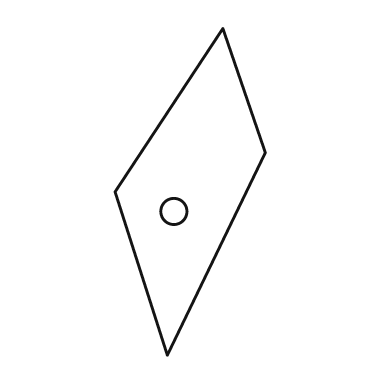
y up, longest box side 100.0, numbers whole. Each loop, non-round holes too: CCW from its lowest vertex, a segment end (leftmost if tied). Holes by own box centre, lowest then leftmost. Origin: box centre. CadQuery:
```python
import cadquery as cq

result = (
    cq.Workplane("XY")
    .moveTo(-7.0, -50.0)
    .lineTo(23.0, 12.0)
    .lineTo(10.0, 50.0)
    .lineTo(-23.0, 0.0)
    .close()
    .moveTo(-5.0, -6.0)
    .circle(4.0)
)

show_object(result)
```